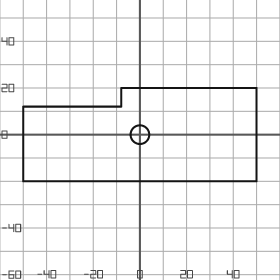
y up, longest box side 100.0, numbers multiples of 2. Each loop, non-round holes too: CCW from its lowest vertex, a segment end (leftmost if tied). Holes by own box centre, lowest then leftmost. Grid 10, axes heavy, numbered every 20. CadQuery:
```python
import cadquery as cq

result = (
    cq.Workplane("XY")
    .moveTo(-50.0, -20.0)
    .lineTo(50.0, -20.0)
    .lineTo(50.0, 20.0)
    .lineTo(-8.0, 20.0)
    .lineTo(-8.0, 12.0)
    .lineTo(-50.0, 12.0)
    .close()
    .moveTo(0.0, 0.0)
    .circle(4.0)
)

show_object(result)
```